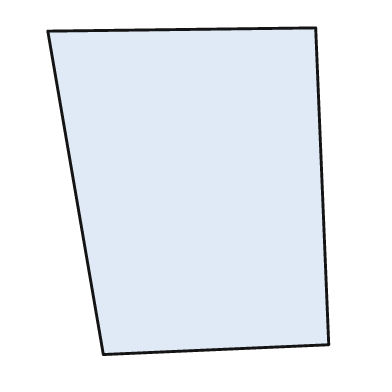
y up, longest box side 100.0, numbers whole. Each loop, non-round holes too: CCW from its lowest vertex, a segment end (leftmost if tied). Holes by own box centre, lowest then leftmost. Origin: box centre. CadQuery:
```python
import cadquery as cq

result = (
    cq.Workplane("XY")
    .moveTo(-26.0, -50.0)
    .lineTo(43.0, -47.0)
    .lineTo(39.0, 50.0)
    .lineTo(-43.0, 49.0)
    .close()
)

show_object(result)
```